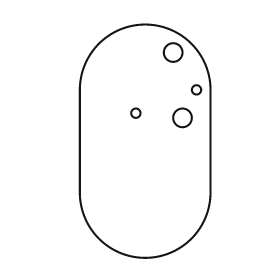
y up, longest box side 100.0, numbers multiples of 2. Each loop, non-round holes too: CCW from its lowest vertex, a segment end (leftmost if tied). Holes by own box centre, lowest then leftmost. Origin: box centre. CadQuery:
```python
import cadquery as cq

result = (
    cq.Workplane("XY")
    .moveTo(-28.0, -22.0)
    .threePointArc((0.0, -50.0), (28.0, -22.0))
    .lineTo(28.0, 22.0)
    .threePointArc((0.0, 50.0), (-28.0, 22.0))
    .close()
    .moveTo(16.0, 10.0)
    .circle(4.0)
    .moveTo(-4.0, 12.0)
    .circle(2.0)
    .moveTo(22.0, 22.0)
    .circle(2.0)
    .moveTo(12.0, 38.0)
    .circle(4.0)
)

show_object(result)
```